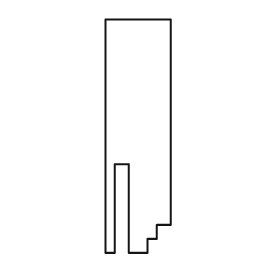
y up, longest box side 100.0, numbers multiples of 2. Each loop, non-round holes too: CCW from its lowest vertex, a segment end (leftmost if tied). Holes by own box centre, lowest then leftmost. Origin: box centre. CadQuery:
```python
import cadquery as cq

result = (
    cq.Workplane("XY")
    .moveTo(-14.0, -50.0)
    .lineTo(-10.0, -50.0)
    .lineTo(-10.0, -12.0)
    .lineTo(-4.0, -12.0)
    .lineTo(-4.0, -50.0)
    .lineTo(4.0, -50.0)
    .lineTo(4.0, -44.0)
    .lineTo(8.0, -44.0)
    .lineTo(8.0, -38.0)
    .lineTo(14.0, -38.0)
    .lineTo(14.0, 50.0)
    .lineTo(-14.0, 50.0)
    .close()
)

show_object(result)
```